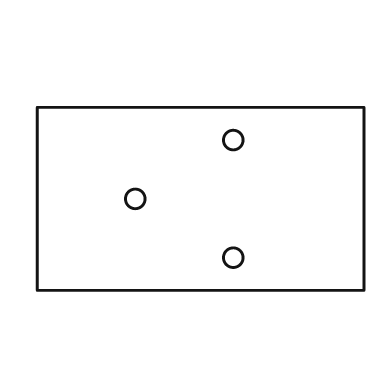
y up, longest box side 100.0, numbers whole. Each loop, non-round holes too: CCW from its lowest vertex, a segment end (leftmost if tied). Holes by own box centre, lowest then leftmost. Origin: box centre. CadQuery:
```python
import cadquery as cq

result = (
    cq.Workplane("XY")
    .moveTo(-50.0, -28.0)
    .lineTo(50.0, -28.0)
    .lineTo(50.0, 28.0)
    .lineTo(-50.0, 28.0)
    .close()
    .moveTo(10.0, -18.0)
    .circle(3.0)
    .moveTo(-20.0, 0.0)
    .circle(3.0)
    .moveTo(10.0, 18.0)
    .circle(3.0)
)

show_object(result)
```